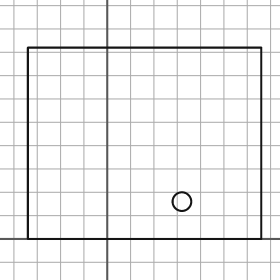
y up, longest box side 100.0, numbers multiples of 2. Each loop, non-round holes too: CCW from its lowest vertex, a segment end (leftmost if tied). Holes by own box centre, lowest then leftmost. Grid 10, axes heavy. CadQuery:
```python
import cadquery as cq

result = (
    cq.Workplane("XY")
    .moveTo(-34.0, 0.0)
    .lineTo(66.0, 0.0)
    .lineTo(66.0, 82.0)
    .lineTo(-34.0, 82.0)
    .close()
    .moveTo(32.0, 16.0)
    .circle(4.0)
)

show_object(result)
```